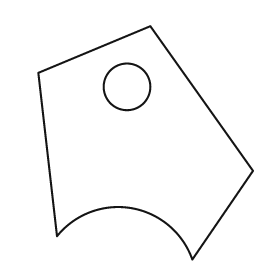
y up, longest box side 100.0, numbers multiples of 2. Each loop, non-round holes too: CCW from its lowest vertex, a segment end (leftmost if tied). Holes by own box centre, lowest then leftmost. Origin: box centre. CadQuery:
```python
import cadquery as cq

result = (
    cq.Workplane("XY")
    .moveTo(20.0, -50.0)
    .lineTo(46.0, -12.0)
    .lineTo(2.0, 50.0)
    .lineTo(-46.0, 30.0)
    .lineTo(-38.0, -40.0)
    .threePointArc((-6.0, -28.0), (20.0, -50.0))
    .close()
    .moveTo(-8.0, 24.0)
    .circle(10.0)
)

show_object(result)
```